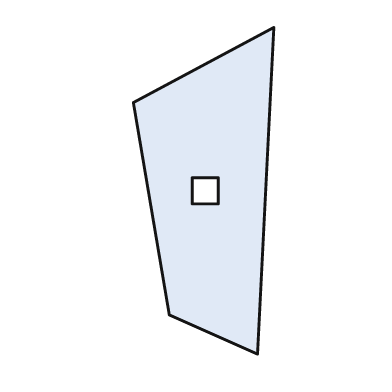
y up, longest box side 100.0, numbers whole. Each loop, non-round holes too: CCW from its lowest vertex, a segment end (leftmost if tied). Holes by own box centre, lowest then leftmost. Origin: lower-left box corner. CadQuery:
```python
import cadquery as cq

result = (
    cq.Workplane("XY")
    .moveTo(38.0, 0.0)
    .lineTo(43.0, 100.0)
    .lineTo(0.0, 77.0)
    .lineTo(11.0, 12.0)
    .close()
    .moveTo(18.0, 46.0)
    .lineTo(26.0, 46.0)
    .lineTo(26.0, 54.0)
    .lineTo(18.0, 54.0)
    .close()
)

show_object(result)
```